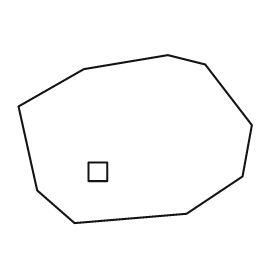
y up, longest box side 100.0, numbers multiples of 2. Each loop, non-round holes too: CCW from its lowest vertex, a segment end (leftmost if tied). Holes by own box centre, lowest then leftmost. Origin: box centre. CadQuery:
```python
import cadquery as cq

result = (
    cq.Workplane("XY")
    .moveTo(-26.0, -36.0)
    .lineTo(22.0, -32.0)
    .lineTo(46.0, -16.0)
    .lineTo(50.0, 6.0)
    .lineTo(30.0, 32.0)
    .lineTo(14.0, 36.0)
    .lineTo(-22.0, 30.0)
    .lineTo(-50.0, 14.0)
    .lineTo(-42.0, -22.0)
    .close()
    .moveTo(-20.0, -18.0)
    .lineTo(-12.0, -18.0)
    .lineTo(-12.0, -10.0)
    .lineTo(-20.0, -10.0)
    .close()
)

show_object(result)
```